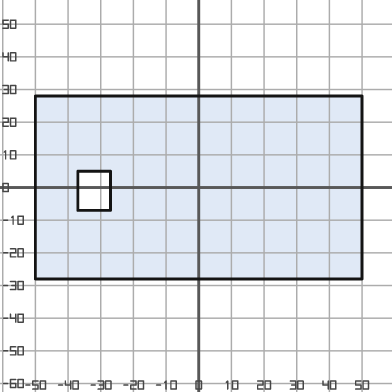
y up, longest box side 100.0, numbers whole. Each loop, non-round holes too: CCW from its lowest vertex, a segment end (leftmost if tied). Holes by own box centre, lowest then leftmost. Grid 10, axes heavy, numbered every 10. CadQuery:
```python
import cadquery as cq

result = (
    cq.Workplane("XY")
    .moveTo(-50.0, -28.0)
    .lineTo(50.0, -28.0)
    .lineTo(50.0, 28.0)
    .lineTo(-50.0, 28.0)
    .close()
    .moveTo(-37.0, -7.0)
    .lineTo(-27.0, -7.0)
    .lineTo(-27.0, 5.0)
    .lineTo(-37.0, 5.0)
    .close()
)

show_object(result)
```